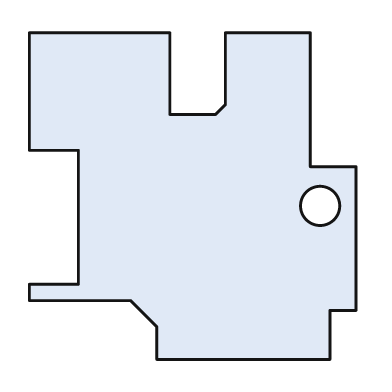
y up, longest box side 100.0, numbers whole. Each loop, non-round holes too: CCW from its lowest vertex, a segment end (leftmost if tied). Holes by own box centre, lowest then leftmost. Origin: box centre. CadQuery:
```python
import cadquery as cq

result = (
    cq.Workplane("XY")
    .moveTo(-11.0, -50.0)
    .lineTo(42.0, -50.0)
    .lineTo(42.0, -35.0)
    .lineTo(50.0, -35.0)
    .lineTo(50.0, 9.0)
    .lineTo(36.0, 9.0)
    .lineTo(36.0, 50.0)
    .lineTo(10.0, 50.0)
    .lineTo(10.0, 28.0)
    .lineTo(7.0, 25.0)
    .lineTo(-7.0, 25.0)
    .lineTo(-7.0, 50.0)
    .lineTo(-50.0, 50.0)
    .lineTo(-50.0, 14.0)
    .lineTo(-35.0, 14.0)
    .lineTo(-35.0, -27.0)
    .lineTo(-50.0, -27.0)
    .lineTo(-50.0, -32.0)
    .lineTo(-19.0, -32.0)
    .lineTo(-11.0, -40.0)
    .close()
    .moveTo(39.0, -3.0)
    .circle(6.0)
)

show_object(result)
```